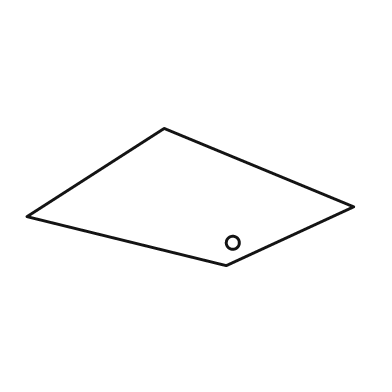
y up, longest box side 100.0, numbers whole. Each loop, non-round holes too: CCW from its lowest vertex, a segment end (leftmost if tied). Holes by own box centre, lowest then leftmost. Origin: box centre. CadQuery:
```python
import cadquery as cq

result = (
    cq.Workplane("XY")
    .moveTo(11.0, -21.0)
    .lineTo(50.0, -3.0)
    .lineTo(-8.0, 21.0)
    .lineTo(-50.0, -6.0)
    .close()
    .moveTo(13.0, -14.0)
    .circle(2.0)
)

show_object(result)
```